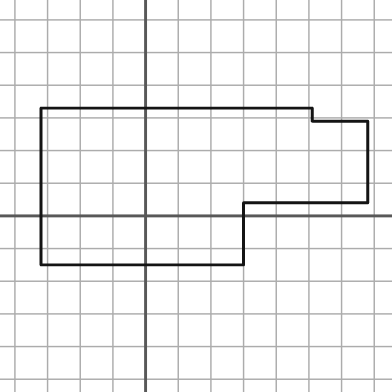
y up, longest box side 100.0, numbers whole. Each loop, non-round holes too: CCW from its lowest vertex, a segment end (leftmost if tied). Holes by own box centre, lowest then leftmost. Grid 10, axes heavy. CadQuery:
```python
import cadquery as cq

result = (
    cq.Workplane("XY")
    .moveTo(-32.0, -15.0)
    .lineTo(30.0, -15.0)
    .lineTo(30.0, 4.0)
    .lineTo(68.0, 4.0)
    .lineTo(68.0, 29.0)
    .lineTo(51.0, 29.0)
    .lineTo(51.0, 33.0)
    .lineTo(-32.0, 33.0)
    .close()
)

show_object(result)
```